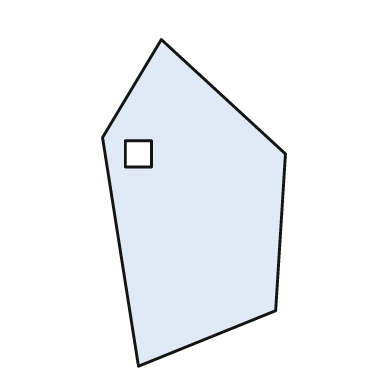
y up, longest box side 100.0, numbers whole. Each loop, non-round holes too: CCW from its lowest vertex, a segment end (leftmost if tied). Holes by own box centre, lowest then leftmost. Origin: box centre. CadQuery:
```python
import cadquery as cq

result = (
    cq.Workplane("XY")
    .moveTo(-17.0, -50.0)
    .lineTo(25.0, -33.0)
    .lineTo(28.0, 15.0)
    .lineTo(-10.0, 50.0)
    .lineTo(-28.0, 20.0)
    .close()
    .moveTo(-21.0, 11.0)
    .lineTo(-13.0, 11.0)
    .lineTo(-13.0, 19.0)
    .lineTo(-21.0, 19.0)
    .close()
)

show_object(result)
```